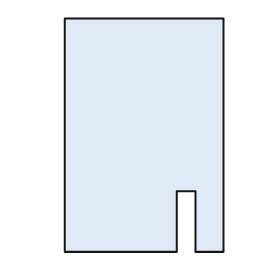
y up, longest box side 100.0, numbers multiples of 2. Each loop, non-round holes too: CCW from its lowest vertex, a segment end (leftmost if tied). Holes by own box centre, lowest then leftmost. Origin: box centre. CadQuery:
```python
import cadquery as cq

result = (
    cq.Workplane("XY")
    .moveTo(-34.0, -50.0)
    .lineTo(14.0, -50.0)
    .lineTo(14.0, -24.0)
    .lineTo(22.0, -24.0)
    .lineTo(22.0, -50.0)
    .lineTo(34.0, -50.0)
    .lineTo(34.0, 50.0)
    .lineTo(-34.0, 50.0)
    .close()
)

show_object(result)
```